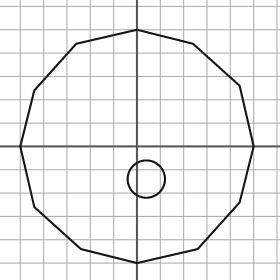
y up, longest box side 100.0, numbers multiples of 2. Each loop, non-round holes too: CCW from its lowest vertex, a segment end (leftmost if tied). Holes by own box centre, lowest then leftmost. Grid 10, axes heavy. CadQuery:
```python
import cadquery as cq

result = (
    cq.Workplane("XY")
    .moveTo(0.0, -50.0)
    .lineTo(26.0, -44.0)
    .lineTo(44.0, -24.0)
    .lineTo(50.0, 0.0)
    .lineTo(44.0, 26.0)
    .lineTo(24.0, 44.0)
    .lineTo(0.0, 50.0)
    .lineTo(-26.0, 44.0)
    .lineTo(-44.0, 24.0)
    .lineTo(-50.0, 0.0)
    .lineTo(-44.0, -26.0)
    .lineTo(-24.0, -44.0)
    .close()
    .moveTo(4.0, -14.0)
    .circle(8.0)
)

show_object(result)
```